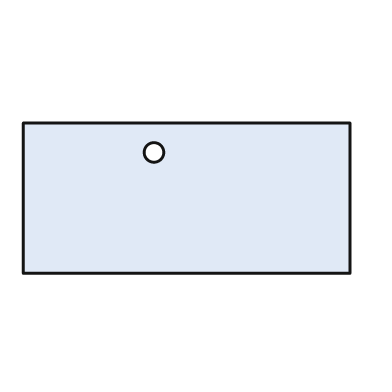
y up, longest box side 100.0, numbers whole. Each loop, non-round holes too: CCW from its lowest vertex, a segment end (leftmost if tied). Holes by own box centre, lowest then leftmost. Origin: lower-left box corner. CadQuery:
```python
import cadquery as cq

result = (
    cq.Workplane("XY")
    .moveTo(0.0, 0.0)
    .lineTo(100.0, 0.0)
    .lineTo(100.0, 46.0)
    .lineTo(0.0, 46.0)
    .close()
    .moveTo(40.0, 37.0)
    .circle(3.0)
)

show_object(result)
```